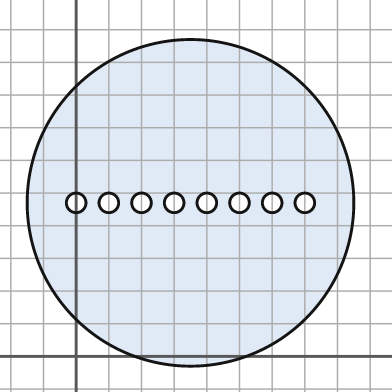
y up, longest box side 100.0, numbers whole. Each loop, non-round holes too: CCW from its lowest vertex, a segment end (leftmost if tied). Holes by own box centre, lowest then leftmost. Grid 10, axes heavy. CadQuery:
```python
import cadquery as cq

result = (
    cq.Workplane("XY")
    .moveTo(35.0, 47.0)
    .circle(50.0)
    .moveTo(0.0, 47.0)
    .circle(3.0)
    .moveTo(10.0, 47.0)
    .circle(3.0)
    .moveTo(20.0, 47.0)
    .circle(3.0)
    .moveTo(30.0, 47.0)
    .circle(3.0)
    .moveTo(40.0, 47.0)
    .circle(3.0)
    .moveTo(50.0, 47.0)
    .circle(3.0)
    .moveTo(60.0, 47.0)
    .circle(3.0)
    .moveTo(70.0, 47.0)
    .circle(3.0)
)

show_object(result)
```